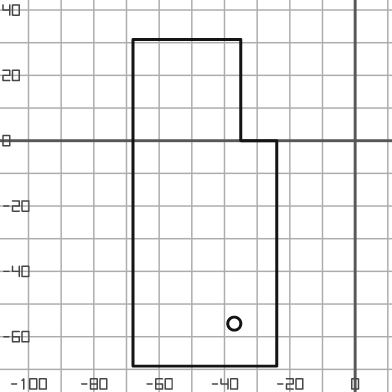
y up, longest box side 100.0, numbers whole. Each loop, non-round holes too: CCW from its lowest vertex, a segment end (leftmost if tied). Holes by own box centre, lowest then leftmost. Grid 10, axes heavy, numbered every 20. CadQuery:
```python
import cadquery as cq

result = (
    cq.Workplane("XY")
    .moveTo(-68.0, -69.0)
    .lineTo(-24.0, -69.0)
    .lineTo(-24.0, 0.0)
    .lineTo(-35.0, 0.0)
    .lineTo(-35.0, 31.0)
    .lineTo(-68.0, 31.0)
    .close()
    .moveTo(-37.0, -56.0)
    .circle(2.0)
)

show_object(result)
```